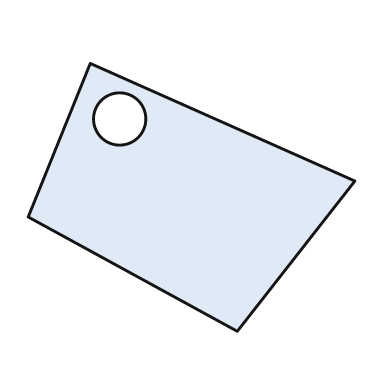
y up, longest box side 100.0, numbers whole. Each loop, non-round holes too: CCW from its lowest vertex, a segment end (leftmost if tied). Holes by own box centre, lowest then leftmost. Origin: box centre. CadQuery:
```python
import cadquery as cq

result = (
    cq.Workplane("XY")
    .moveTo(14.0, -41.0)
    .lineTo(50.0, 5.0)
    .lineTo(-31.0, 41.0)
    .lineTo(-50.0, -6.0)
    .close()
    .moveTo(-22.0, 24.0)
    .circle(8.0)
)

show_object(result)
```